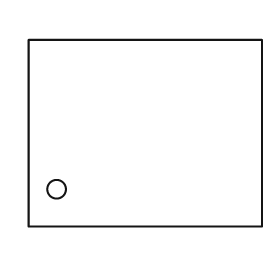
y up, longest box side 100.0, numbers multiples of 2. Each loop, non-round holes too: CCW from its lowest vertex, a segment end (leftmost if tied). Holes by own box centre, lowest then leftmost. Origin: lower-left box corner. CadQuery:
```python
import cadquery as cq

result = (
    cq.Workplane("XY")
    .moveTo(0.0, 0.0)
    .lineTo(100.0, 0.0)
    .lineTo(100.0, 80.0)
    .lineTo(0.0, 80.0)
    .close()
    .moveTo(12.0, 16.0)
    .circle(4.0)
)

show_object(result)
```